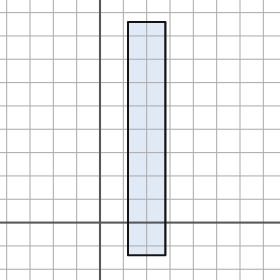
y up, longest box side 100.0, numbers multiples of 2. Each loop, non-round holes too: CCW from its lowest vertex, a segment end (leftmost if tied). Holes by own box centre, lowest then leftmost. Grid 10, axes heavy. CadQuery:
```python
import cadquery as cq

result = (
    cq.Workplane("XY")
    .moveTo(12.0, -14.0)
    .lineTo(28.0, -14.0)
    .lineTo(28.0, 86.0)
    .lineTo(12.0, 86.0)
    .close()
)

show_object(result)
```